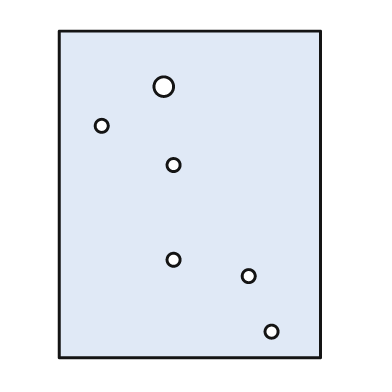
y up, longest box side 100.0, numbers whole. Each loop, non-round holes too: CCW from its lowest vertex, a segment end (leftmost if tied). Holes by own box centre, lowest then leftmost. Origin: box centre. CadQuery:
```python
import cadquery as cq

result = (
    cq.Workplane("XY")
    .moveTo(-40.0, -50.0)
    .lineTo(40.0, -50.0)
    .lineTo(40.0, 50.0)
    .lineTo(-40.0, 50.0)
    .close()
    .moveTo(25.0, -42.0)
    .circle(2.0)
    .moveTo(18.0, -25.0)
    .circle(2.0)
    .moveTo(-5.0, -20.0)
    .circle(2.0)
    .moveTo(-5.0, 9.0)
    .circle(2.0)
    .moveTo(-27.0, 21.0)
    .circle(2.0)
    .moveTo(-8.0, 33.0)
    .circle(3.0)
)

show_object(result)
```